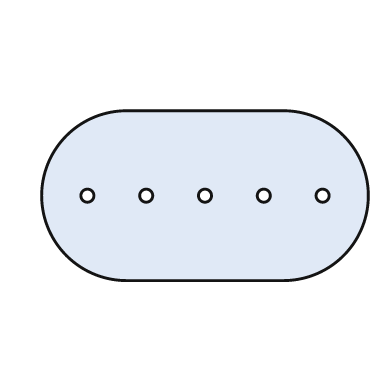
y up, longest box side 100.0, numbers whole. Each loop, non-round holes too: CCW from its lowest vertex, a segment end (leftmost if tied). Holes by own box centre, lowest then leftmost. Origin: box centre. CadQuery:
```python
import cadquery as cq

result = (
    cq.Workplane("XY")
    .moveTo(-24.0, -26.0)
    .lineTo(24.0, -26.0)
    .threePointArc((50.0, 0.0), (24.0, 26.0))
    .lineTo(-24.0, 26.0)
    .threePointArc((-50.0, 0.0), (-24.0, -26.0))
    .close()
    .moveTo(-36.0, 0.0)
    .circle(2.0)
    .moveTo(-18.0, 0.0)
    .circle(2.0)
    .moveTo(0.0, 0.0)
    .circle(2.0)
    .moveTo(18.0, 0.0)
    .circle(2.0)
    .moveTo(36.0, 0.0)
    .circle(2.0)
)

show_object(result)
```